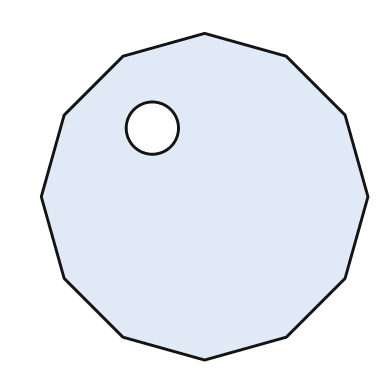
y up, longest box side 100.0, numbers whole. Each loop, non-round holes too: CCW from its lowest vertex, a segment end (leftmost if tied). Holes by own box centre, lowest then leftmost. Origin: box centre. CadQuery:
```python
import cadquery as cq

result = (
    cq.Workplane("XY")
    .moveTo(0.0, -50.0)
    .lineTo(25.0, -43.0)
    .lineTo(43.0, -25.0)
    .lineTo(50.0, 0.0)
    .lineTo(43.0, 25.0)
    .lineTo(25.0, 43.0)
    .lineTo(0.0, 50.0)
    .lineTo(-25.0, 43.0)
    .lineTo(-43.0, 25.0)
    .lineTo(-50.0, 0.0)
    .lineTo(-43.0, -25.0)
    .lineTo(-25.0, -43.0)
    .close()
    .moveTo(-16.0, 21.0)
    .circle(8.0)
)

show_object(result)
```